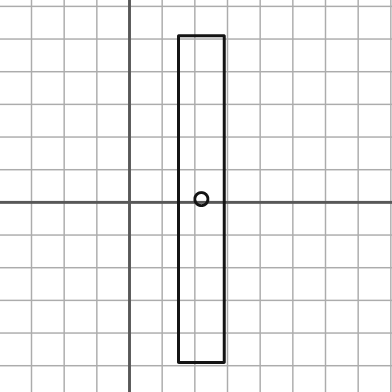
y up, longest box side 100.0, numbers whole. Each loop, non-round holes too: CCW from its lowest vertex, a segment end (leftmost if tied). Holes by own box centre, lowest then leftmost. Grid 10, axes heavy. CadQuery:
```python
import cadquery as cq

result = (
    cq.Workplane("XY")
    .moveTo(15.0, -49.0)
    .lineTo(29.0, -49.0)
    .lineTo(29.0, 51.0)
    .lineTo(15.0, 51.0)
    .close()
    .moveTo(22.0, 1.0)
    .circle(2.0)
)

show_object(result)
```